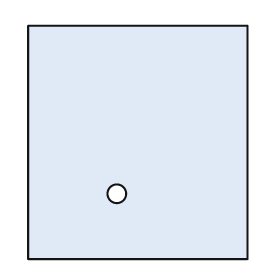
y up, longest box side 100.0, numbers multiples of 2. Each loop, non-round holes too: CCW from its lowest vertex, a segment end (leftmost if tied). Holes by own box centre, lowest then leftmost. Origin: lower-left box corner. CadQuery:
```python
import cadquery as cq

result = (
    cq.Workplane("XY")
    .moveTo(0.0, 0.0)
    .lineTo(94.0, 0.0)
    .lineTo(94.0, 100.0)
    .lineTo(0.0, 100.0)
    .close()
    .moveTo(38.0, 28.0)
    .circle(4.0)
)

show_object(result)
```